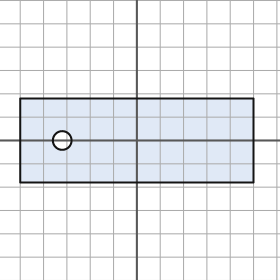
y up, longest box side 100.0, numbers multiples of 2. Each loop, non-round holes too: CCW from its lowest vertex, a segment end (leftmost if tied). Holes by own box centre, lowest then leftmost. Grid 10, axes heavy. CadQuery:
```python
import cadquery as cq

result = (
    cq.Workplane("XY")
    .moveTo(-50.0, -18.0)
    .lineTo(50.0, -18.0)
    .lineTo(50.0, 18.0)
    .lineTo(-50.0, 18.0)
    .close()
    .moveTo(-32.0, 0.0)
    .circle(4.0)
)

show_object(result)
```